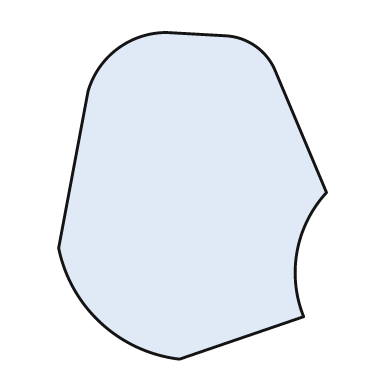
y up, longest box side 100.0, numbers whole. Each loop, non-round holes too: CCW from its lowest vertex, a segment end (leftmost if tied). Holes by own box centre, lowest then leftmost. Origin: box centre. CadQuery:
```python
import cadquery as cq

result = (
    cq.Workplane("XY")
    .moveTo(-4.0, -50.0)
    .lineTo(34.0, -37.0)
    .threePointArc((32.0, -17.0), (41.0, 1.0))
    .lineTo(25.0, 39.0)
    .threePointArc((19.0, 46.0), (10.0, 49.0))
    .lineTo(-8.0, 50.0)
    .threePointArc((-23.0, 45.0), (-32.0, 32.0))
    .lineTo(-41.0, -16.0)
    .threePointArc((-28.0, -39.0), (-4.0, -50.0))
    .close()
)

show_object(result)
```